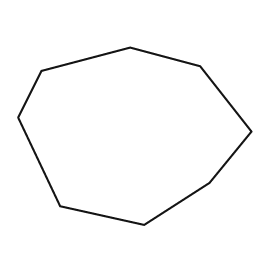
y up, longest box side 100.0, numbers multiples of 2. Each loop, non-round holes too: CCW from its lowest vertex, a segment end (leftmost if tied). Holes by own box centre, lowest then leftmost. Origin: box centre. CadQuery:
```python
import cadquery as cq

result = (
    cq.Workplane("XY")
    .moveTo(4.0, -38.0)
    .lineTo(32.0, -20.0)
    .lineTo(50.0, 2.0)
    .lineTo(28.0, 30.0)
    .lineTo(-2.0, 38.0)
    .lineTo(-40.0, 28.0)
    .lineTo(-50.0, 8.0)
    .lineTo(-32.0, -30.0)
    .close()
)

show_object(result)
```